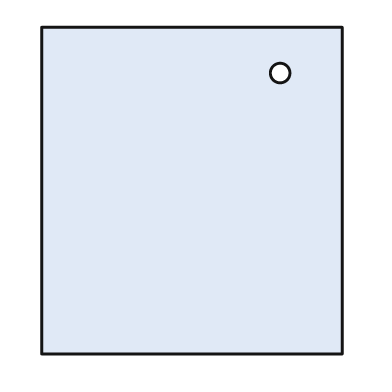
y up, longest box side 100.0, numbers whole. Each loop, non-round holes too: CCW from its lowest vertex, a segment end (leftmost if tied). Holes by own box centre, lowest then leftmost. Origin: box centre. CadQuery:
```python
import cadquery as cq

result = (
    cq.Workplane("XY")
    .moveTo(-46.0, -50.0)
    .lineTo(46.0, -50.0)
    .lineTo(46.0, 50.0)
    .lineTo(-46.0, 50.0)
    .close()
    .moveTo(27.0, 36.0)
    .circle(3.0)
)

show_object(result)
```